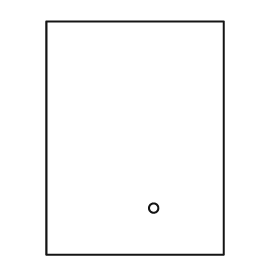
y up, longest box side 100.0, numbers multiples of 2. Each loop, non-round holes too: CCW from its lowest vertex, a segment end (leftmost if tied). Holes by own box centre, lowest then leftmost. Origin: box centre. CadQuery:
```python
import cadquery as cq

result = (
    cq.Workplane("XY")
    .moveTo(-38.0, -50.0)
    .lineTo(38.0, -50.0)
    .lineTo(38.0, 50.0)
    .lineTo(-38.0, 50.0)
    .close()
    .moveTo(8.0, -30.0)
    .circle(2.0)
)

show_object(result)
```